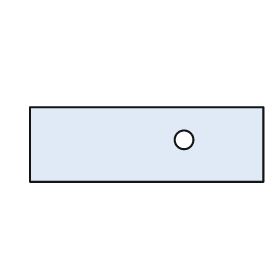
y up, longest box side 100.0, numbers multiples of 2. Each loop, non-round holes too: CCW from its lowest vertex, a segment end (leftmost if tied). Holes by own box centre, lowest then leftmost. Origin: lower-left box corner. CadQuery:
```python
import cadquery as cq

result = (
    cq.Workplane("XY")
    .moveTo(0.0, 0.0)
    .lineTo(100.0, 0.0)
    .lineTo(100.0, 32.0)
    .lineTo(0.0, 32.0)
    .close()
    .moveTo(66.0, 18.0)
    .circle(4.0)
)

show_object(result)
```